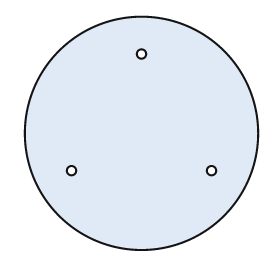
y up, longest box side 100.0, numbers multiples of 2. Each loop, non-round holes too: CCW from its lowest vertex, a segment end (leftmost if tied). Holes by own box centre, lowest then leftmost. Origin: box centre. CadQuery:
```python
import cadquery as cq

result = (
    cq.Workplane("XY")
    .moveTo(0.0, 0.0)
    .circle(50.0)
    .moveTo(-30.0, -16.0)
    .circle(2.0)
    .moveTo(30.0, -16.0)
    .circle(2.0)
    .moveTo(0.0, 34.0)
    .circle(2.0)
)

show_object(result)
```